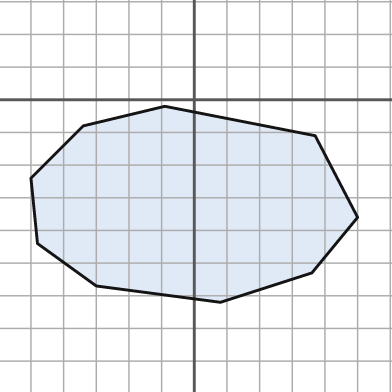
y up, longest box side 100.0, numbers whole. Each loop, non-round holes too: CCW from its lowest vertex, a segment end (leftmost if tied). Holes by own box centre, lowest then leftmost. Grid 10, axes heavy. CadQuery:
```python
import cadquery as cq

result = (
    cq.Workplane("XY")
    .moveTo(8.0, -62.0)
    .lineTo(36.0, -53.0)
    .lineTo(50.0, -36.0)
    .lineTo(37.0, -11.0)
    .lineTo(-9.0, -2.0)
    .lineTo(-34.0, -8.0)
    .lineTo(-50.0, -24.0)
    .lineTo(-48.0, -44.0)
    .lineTo(-30.0, -57.0)
    .close()
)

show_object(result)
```